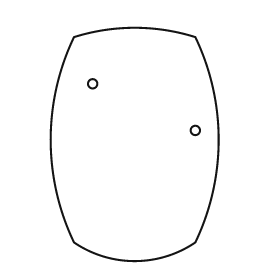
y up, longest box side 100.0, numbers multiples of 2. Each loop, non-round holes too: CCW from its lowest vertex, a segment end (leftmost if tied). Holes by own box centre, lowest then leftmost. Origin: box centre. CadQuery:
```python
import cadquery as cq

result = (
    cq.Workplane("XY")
    .moveTo(-26.0, -42.0)
    .threePointArc((0.0, -50.0), (26.0, -42.0))
    .threePointArc((36.0, 2.0), (26.0, 46.0))
    .threePointArc((0.0, 50.0), (-26.0, 46.0))
    .threePointArc((-36.0, 2.0), (-26.0, -42.0))
    .close()
    .moveTo(26.0, 6.0)
    .circle(2.0)
    .moveTo(-18.0, 26.0)
    .circle(2.0)
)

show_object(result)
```